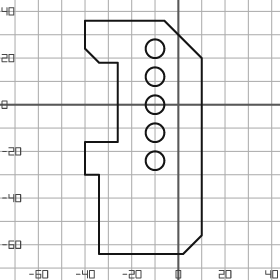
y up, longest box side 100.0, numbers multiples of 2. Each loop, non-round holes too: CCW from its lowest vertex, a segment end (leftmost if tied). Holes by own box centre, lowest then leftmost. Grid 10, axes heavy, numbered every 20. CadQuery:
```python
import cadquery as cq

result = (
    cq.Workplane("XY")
    .moveTo(-34.0, -64.0)
    .lineTo(2.0, -64.0)
    .lineTo(10.0, -56.0)
    .lineTo(10.0, 20.0)
    .lineTo(-6.0, 36.0)
    .lineTo(-40.0, 36.0)
    .lineTo(-40.0, 24.0)
    .lineTo(-34.0, 18.0)
    .lineTo(-26.0, 18.0)
    .lineTo(-26.0, -16.0)
    .lineTo(-40.0, -16.0)
    .lineTo(-40.0, -30.0)
    .lineTo(-34.0, -30.0)
    .close()
    .moveTo(-10.0, -24.0)
    .circle(4.0)
    .moveTo(-10.0, -12.0)
    .circle(4.0)
    .moveTo(-10.0, 0.0)
    .circle(4.0)
    .moveTo(-10.0, 12.0)
    .circle(4.0)
    .moveTo(-10.0, 24.0)
    .circle(4.0)
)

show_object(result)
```